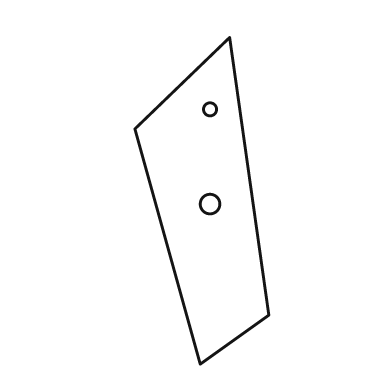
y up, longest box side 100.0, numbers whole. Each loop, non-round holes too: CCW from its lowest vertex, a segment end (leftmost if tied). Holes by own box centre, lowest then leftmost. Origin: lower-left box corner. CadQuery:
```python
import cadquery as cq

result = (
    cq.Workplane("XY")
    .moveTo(20.0, 0.0)
    .lineTo(41.0, 15.0)
    .lineTo(29.0, 100.0)
    .lineTo(0.0, 72.0)
    .close()
    .moveTo(23.0, 49.0)
    .circle(3.0)
    .moveTo(23.0, 78.0)
    .circle(2.0)
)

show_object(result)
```